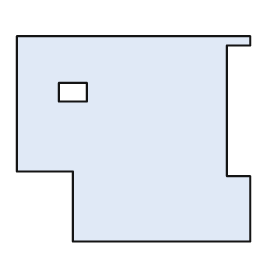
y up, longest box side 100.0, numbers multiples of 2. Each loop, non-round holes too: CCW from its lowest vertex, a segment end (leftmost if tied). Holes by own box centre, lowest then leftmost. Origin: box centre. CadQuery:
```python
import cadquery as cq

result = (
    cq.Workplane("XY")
    .moveTo(-26.0, -44.0)
    .lineTo(50.0, -44.0)
    .lineTo(50.0, -16.0)
    .lineTo(40.0, -16.0)
    .lineTo(40.0, 40.0)
    .lineTo(50.0, 40.0)
    .lineTo(50.0, 44.0)
    .lineTo(-50.0, 44.0)
    .lineTo(-50.0, -14.0)
    .lineTo(-26.0, -14.0)
    .close()
    .moveTo(-32.0, 16.0)
    .lineTo(-20.0, 16.0)
    .lineTo(-20.0, 24.0)
    .lineTo(-32.0, 24.0)
    .close()
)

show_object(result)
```